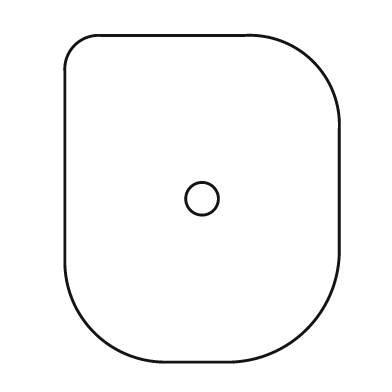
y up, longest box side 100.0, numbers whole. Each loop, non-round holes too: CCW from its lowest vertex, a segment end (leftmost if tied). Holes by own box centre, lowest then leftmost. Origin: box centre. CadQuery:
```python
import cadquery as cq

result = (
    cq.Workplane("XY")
    .moveTo(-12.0, -50.0)
    .lineTo(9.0, -50.0)
    .threePointArc((32.0, -40.0), (42.0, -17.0))
    .lineTo(42.0, 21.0)
    .threePointArc((34.0, 42.0), (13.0, 50.0))
    .lineTo(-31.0, 50.0)
    .threePointArc((-39.0, 47.0), (-42.0, 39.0))
    .lineTo(-42.0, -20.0)
    .threePointArc((-33.0, -41.0), (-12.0, -50.0))
    .close()
    .moveTo(0.0, 0.0)
    .circle(5.0)
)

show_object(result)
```